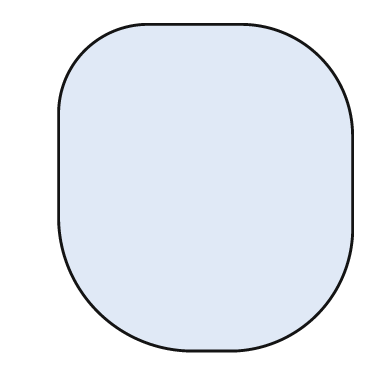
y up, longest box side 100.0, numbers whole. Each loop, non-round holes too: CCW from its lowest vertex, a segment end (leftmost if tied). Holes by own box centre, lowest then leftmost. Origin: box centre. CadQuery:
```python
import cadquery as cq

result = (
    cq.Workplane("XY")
    .moveTo(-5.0, -50.0)
    .lineTo(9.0, -50.0)
    .threePointArc((34.0, -39.0), (45.0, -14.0))
    .lineTo(45.0, 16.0)
    .threePointArc((35.0, 40.0), (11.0, 50.0))
    .lineTo(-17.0, 50.0)
    .threePointArc((-37.0, 42.0), (-45.0, 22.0))
    .lineTo(-45.0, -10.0)
    .threePointArc((-33.0, -38.0), (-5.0, -50.0))
    .close()
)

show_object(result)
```